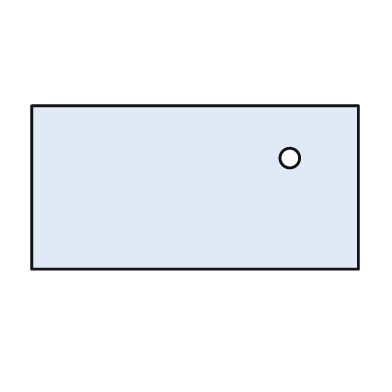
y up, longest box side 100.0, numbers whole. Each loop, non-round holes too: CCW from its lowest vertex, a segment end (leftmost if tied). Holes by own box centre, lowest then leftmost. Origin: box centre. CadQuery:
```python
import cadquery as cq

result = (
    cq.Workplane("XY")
    .moveTo(-50.0, -25.0)
    .lineTo(50.0, -25.0)
    .lineTo(50.0, 25.0)
    .lineTo(-50.0, 25.0)
    .close()
    .moveTo(29.0, 9.0)
    .circle(3.0)
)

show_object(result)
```